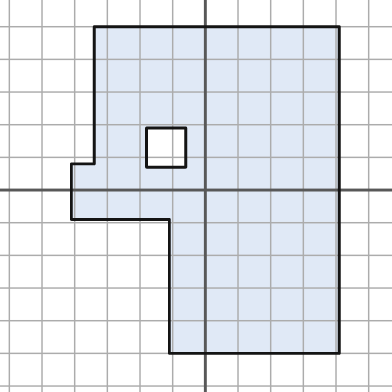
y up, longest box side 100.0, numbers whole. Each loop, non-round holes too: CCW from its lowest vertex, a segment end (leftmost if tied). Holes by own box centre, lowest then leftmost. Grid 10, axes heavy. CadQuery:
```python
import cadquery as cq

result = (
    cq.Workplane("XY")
    .moveTo(-11.0, -50.0)
    .lineTo(41.0, -50.0)
    .lineTo(41.0, 50.0)
    .lineTo(-34.0, 50.0)
    .lineTo(-34.0, 8.0)
    .lineTo(-41.0, 8.0)
    .lineTo(-41.0, -9.0)
    .lineTo(-11.0, -9.0)
    .close()
    .moveTo(-18.0, 7.0)
    .lineTo(-6.0, 7.0)
    .lineTo(-6.0, 19.0)
    .lineTo(-18.0, 19.0)
    .close()
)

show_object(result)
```